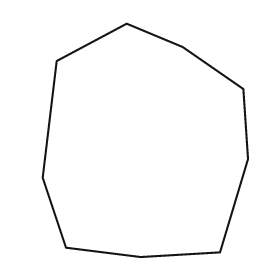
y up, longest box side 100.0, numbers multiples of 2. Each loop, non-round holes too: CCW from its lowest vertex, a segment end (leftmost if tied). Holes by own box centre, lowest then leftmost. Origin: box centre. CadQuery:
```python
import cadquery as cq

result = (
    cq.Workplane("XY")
    .moveTo(-2.0, -50.0)
    .lineTo(32.0, -48.0)
    .lineTo(44.0, -8.0)
    .lineTo(42.0, 22.0)
    .lineTo(16.0, 40.0)
    .lineTo(-8.0, 50.0)
    .lineTo(-38.0, 34.0)
    .lineTo(-44.0, -16.0)
    .lineTo(-34.0, -46.0)
    .close()
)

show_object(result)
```